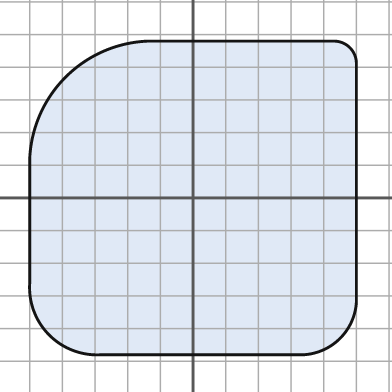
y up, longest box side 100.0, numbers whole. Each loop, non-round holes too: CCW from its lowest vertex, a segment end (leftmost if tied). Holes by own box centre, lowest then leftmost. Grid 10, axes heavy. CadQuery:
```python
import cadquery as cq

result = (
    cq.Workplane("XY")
    .moveTo(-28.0, -48.0)
    .lineTo(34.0, -48.0)
    .threePointArc((45.0, -43.0), (50.0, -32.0))
    .lineTo(50.0, 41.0)
    .threePointArc((48.0, 46.0), (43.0, 48.0))
    .lineTo(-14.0, 48.0)
    .threePointArc((-39.0, 37.0), (-50.0, 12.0))
    .lineTo(-50.0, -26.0)
    .threePointArc((-44.0, -42.0), (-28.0, -48.0))
    .close()
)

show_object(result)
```